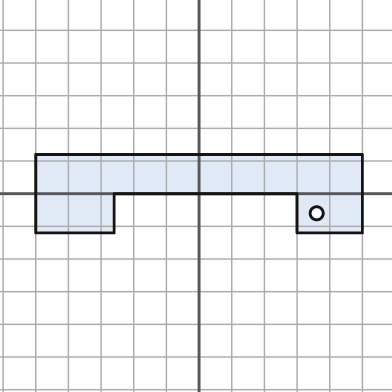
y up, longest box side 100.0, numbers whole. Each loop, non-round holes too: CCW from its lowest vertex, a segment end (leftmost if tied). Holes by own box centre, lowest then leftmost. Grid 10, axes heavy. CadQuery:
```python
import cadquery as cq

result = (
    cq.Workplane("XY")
    .moveTo(-50.0, -12.0)
    .lineTo(-26.0, -12.0)
    .lineTo(-26.0, 0.0)
    .lineTo(30.0, 0.0)
    .lineTo(30.0, -12.0)
    .lineTo(50.0, -12.0)
    .lineTo(50.0, 12.0)
    .lineTo(-50.0, 12.0)
    .close()
    .moveTo(36.0, -6.0)
    .circle(2.0)
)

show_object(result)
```